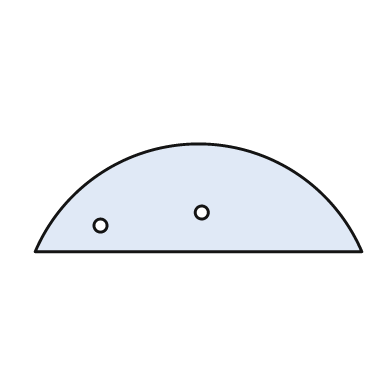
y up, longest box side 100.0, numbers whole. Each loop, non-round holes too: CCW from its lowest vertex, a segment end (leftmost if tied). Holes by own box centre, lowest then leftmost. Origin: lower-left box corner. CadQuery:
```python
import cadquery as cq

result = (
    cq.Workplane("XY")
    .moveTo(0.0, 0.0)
    .lineTo(100.0, 0.0)
    .threePointArc((50.0, 33.0), (0.0, 0.0))
    .close()
    .moveTo(20.0, 8.0)
    .circle(2.0)
    .moveTo(51.0, 12.0)
    .circle(2.0)
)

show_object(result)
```